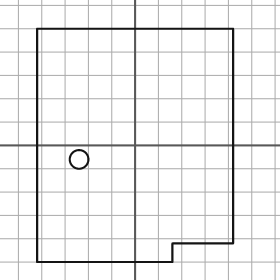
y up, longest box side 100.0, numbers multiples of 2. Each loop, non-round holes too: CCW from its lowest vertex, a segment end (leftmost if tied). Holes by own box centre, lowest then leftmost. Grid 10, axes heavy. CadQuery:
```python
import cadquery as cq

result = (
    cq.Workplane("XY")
    .moveTo(-42.0, -50.0)
    .lineTo(16.0, -50.0)
    .lineTo(16.0, -42.0)
    .lineTo(42.0, -42.0)
    .lineTo(42.0, 50.0)
    .lineTo(-42.0, 50.0)
    .close()
    .moveTo(-24.0, -6.0)
    .circle(4.0)
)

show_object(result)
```